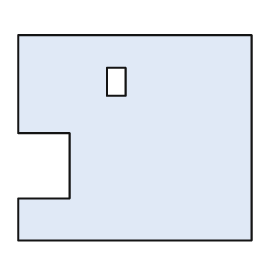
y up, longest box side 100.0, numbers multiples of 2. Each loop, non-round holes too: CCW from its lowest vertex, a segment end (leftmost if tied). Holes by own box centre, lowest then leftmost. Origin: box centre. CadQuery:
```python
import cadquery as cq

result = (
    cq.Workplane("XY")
    .moveTo(-50.0, -44.0)
    .lineTo(50.0, -44.0)
    .lineTo(50.0, 44.0)
    .lineTo(-50.0, 44.0)
    .lineTo(-50.0, 2.0)
    .lineTo(-28.0, 2.0)
    .lineTo(-28.0, -26.0)
    .lineTo(-50.0, -26.0)
    .close()
    .moveTo(-12.0, 18.0)
    .lineTo(-4.0, 18.0)
    .lineTo(-4.0, 30.0)
    .lineTo(-12.0, 30.0)
    .close()
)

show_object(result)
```